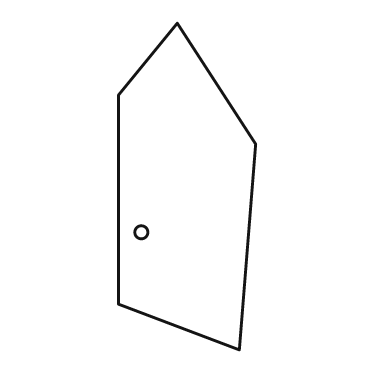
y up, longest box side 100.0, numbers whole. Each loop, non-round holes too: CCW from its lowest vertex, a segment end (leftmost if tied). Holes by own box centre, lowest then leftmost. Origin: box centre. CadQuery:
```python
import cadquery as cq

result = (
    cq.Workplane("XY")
    .moveTo(16.0, -50.0)
    .lineTo(21.0, 13.0)
    .lineTo(-3.0, 50.0)
    .lineTo(-21.0, 28.0)
    .lineTo(-21.0, -36.0)
    .close()
    .moveTo(-14.0, -14.0)
    .circle(2.0)
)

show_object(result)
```